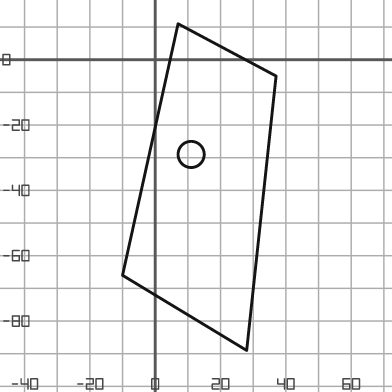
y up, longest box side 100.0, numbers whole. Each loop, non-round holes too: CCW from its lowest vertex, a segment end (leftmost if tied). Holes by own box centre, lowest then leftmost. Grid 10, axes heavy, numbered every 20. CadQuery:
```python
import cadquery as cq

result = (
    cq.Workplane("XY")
    .moveTo(28.0, -89.0)
    .lineTo(37.0, -5.0)
    .lineTo(7.0, 11.0)
    .lineTo(-10.0, -66.0)
    .close()
    .moveTo(11.0, -29.0)
    .circle(4.0)
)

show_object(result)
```